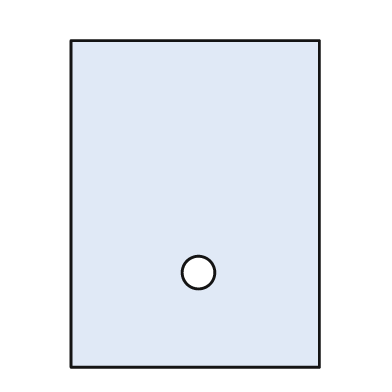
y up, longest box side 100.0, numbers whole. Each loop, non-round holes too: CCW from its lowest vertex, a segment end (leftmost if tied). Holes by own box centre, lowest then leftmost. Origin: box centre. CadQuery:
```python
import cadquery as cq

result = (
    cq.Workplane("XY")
    .moveTo(-38.0, -50.0)
    .lineTo(38.0, -50.0)
    .lineTo(38.0, 50.0)
    .lineTo(-38.0, 50.0)
    .close()
    .moveTo(1.0, -21.0)
    .circle(5.0)
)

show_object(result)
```